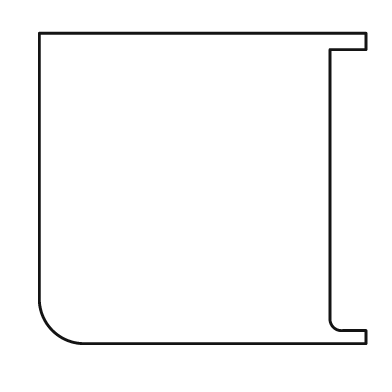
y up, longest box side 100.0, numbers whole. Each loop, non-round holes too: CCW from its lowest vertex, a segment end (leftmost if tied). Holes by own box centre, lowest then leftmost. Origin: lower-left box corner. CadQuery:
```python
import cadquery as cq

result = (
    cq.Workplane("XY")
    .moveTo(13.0, 0.0)
    .lineTo(100.0, 0.0)
    .lineTo(100.0, 4.0)
    .lineTo(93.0, 4.0)
    .threePointArc((90.0, 5.0), (89.0, 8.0))
    .lineTo(89.0, 90.0)
    .lineTo(100.0, 90.0)
    .lineTo(100.0, 95.0)
    .lineTo(0.0, 95.0)
    .lineTo(0.0, 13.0)
    .threePointArc((4.0, 4.0), (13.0, 0.0))
    .close()
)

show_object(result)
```